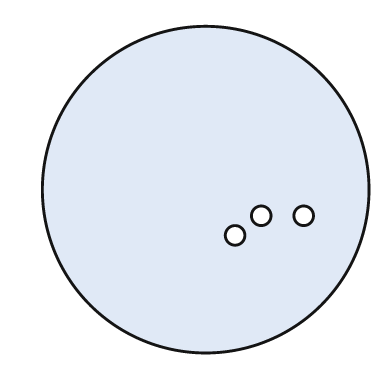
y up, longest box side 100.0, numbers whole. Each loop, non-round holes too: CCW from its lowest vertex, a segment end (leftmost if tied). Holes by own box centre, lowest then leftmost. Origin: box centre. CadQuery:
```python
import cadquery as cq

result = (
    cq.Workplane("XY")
    .moveTo(0.0, 0.0)
    .circle(50.0)
    .moveTo(9.0, -14.0)
    .circle(3.0)
    .moveTo(17.0, -8.0)
    .circle(3.0)
    .moveTo(30.0, -8.0)
    .circle(3.0)
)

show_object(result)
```